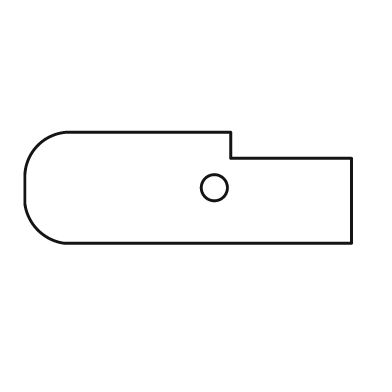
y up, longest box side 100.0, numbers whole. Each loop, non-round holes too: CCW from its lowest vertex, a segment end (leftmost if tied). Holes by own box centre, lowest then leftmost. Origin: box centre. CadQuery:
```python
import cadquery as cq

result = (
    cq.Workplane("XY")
    .moveTo(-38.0, -17.0)
    .lineTo(50.0, -17.0)
    .lineTo(50.0, 9.0)
    .lineTo(13.0, 9.0)
    .lineTo(13.0, 17.0)
    .lineTo(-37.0, 17.0)
    .threePointArc((-46.0, 13.0), (-50.0, 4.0))
    .lineTo(-50.0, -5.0)
    .threePointArc((-46.0, -13.0), (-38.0, -17.0))
    .close()
    .moveTo(8.0, 0.0)
    .circle(4.0)
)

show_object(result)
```